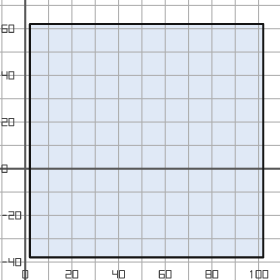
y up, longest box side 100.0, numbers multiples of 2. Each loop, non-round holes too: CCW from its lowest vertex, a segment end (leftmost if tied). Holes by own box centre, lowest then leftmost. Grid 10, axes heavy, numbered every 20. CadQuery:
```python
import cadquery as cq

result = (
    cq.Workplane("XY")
    .moveTo(2.0, -38.0)
    .lineTo(102.0, -38.0)
    .lineTo(102.0, 62.0)
    .lineTo(2.0, 62.0)
    .close()
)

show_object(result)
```